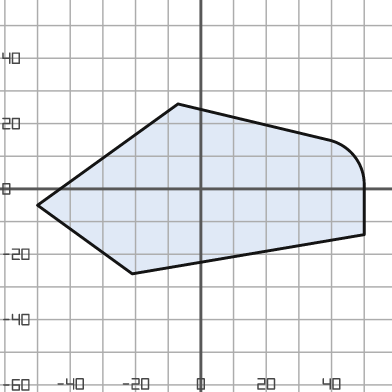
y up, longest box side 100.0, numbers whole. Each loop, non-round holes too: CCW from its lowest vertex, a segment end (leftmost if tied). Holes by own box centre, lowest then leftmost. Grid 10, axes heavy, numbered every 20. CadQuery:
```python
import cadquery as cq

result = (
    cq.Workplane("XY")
    .moveTo(-21.0, -26.0)
    .lineTo(50.0, -14.0)
    .lineTo(50.0, 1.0)
    .threePointArc((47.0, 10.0), (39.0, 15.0))
    .lineTo(-7.0, 26.0)
    .lineTo(-50.0, -5.0)
    .close()
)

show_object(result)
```